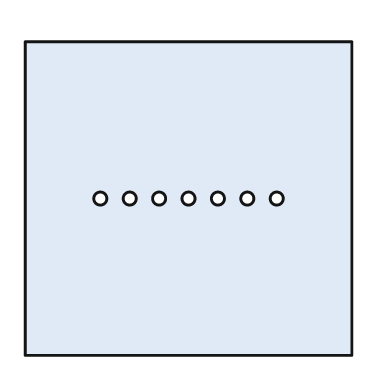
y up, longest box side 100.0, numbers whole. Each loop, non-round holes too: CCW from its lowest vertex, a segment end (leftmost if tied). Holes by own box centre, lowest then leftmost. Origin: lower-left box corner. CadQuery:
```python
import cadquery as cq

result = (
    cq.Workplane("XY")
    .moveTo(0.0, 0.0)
    .lineTo(100.0, 0.0)
    .lineTo(100.0, 96.0)
    .lineTo(0.0, 96.0)
    .close()
    .moveTo(23.0, 48.0)
    .circle(2.0)
    .moveTo(32.0, 48.0)
    .circle(2.0)
    .moveTo(41.0, 48.0)
    .circle(2.0)
    .moveTo(50.0, 48.0)
    .circle(2.0)
    .moveTo(59.0, 48.0)
    .circle(2.0)
    .moveTo(68.0, 48.0)
    .circle(2.0)
    .moveTo(77.0, 48.0)
    .circle(2.0)
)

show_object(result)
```